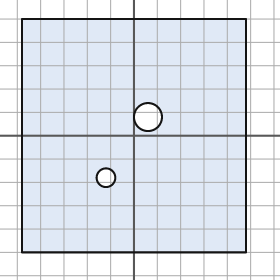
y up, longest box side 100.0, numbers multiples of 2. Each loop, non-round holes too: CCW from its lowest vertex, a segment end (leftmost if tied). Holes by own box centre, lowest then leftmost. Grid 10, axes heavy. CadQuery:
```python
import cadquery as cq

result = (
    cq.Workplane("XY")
    .moveTo(-48.0, -50.0)
    .lineTo(48.0, -50.0)
    .lineTo(48.0, 50.0)
    .lineTo(-48.0, 50.0)
    .close()
    .moveTo(-12.0, -18.0)
    .circle(4.0)
    .moveTo(6.0, 8.0)
    .circle(6.0)
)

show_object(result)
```